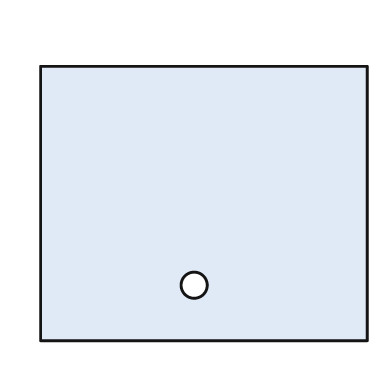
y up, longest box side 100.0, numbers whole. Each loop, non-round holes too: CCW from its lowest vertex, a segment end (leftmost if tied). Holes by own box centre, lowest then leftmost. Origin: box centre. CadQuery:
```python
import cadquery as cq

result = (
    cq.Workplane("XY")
    .moveTo(-50.0, -42.0)
    .lineTo(50.0, -42.0)
    .lineTo(50.0, 42.0)
    .lineTo(-50.0, 42.0)
    .close()
    .moveTo(-3.0, -25.0)
    .circle(4.0)
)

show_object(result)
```